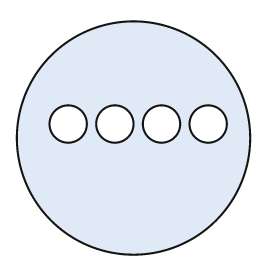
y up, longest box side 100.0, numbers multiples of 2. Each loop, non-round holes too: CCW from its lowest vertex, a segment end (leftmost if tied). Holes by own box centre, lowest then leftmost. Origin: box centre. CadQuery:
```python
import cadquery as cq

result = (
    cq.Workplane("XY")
    .moveTo(0.0, 0.0)
    .circle(50.0)
    .moveTo(-28.0, 6.0)
    .circle(8.0)
    .moveTo(-8.0, 6.0)
    .circle(8.0)
    .moveTo(12.0, 6.0)
    .circle(8.0)
    .moveTo(32.0, 6.0)
    .circle(8.0)
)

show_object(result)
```